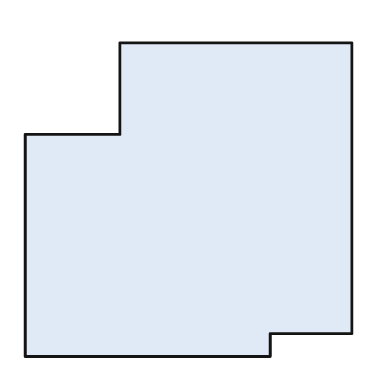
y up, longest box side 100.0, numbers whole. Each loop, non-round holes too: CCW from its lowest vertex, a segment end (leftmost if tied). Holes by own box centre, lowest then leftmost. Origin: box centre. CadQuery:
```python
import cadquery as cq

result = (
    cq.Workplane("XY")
    .moveTo(-50.0, -48.0)
    .lineTo(25.0, -48.0)
    .lineTo(25.0, -41.0)
    .lineTo(50.0, -41.0)
    .lineTo(50.0, 48.0)
    .lineTo(-21.0, 48.0)
    .lineTo(-21.0, 20.0)
    .lineTo(-50.0, 20.0)
    .close()
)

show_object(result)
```